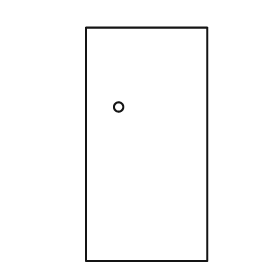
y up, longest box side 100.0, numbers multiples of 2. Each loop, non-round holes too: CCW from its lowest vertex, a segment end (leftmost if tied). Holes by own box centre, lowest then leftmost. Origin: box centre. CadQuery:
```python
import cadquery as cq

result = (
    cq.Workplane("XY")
    .moveTo(-26.0, -50.0)
    .lineTo(26.0, -50.0)
    .lineTo(26.0, 50.0)
    .lineTo(-26.0, 50.0)
    .close()
    .moveTo(-12.0, 16.0)
    .circle(2.0)
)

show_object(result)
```